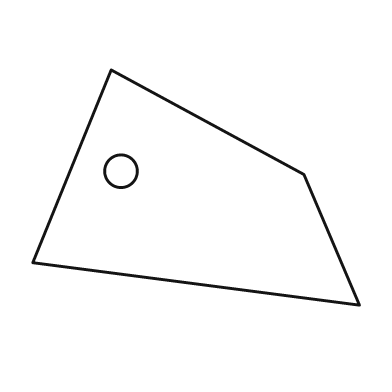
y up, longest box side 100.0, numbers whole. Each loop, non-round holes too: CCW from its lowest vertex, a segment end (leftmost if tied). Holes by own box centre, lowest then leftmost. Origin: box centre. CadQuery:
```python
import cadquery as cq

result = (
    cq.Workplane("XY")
    .moveTo(50.0, -36.0)
    .lineTo(33.0, 4.0)
    .lineTo(-26.0, 36.0)
    .lineTo(-50.0, -23.0)
    .close()
    .moveTo(-23.0, 5.0)
    .circle(5.0)
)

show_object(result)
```